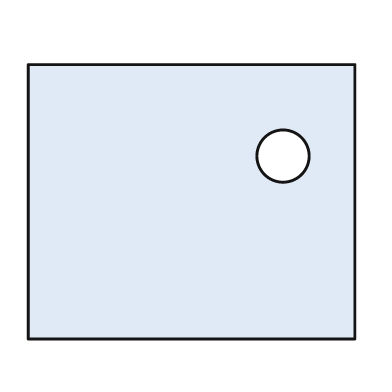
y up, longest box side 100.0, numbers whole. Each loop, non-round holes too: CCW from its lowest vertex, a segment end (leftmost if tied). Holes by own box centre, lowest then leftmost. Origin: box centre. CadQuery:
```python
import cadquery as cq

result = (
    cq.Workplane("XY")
    .moveTo(-50.0, -42.0)
    .lineTo(50.0, -42.0)
    .lineTo(50.0, 42.0)
    .lineTo(-50.0, 42.0)
    .close()
    .moveTo(28.0, 14.0)
    .circle(8.0)
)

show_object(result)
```